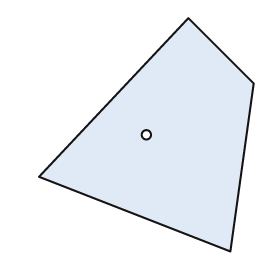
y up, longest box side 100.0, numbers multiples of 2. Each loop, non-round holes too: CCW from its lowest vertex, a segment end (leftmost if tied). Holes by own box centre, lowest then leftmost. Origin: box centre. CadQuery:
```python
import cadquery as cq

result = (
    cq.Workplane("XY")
    .moveTo(36.0, -50.0)
    .lineTo(46.0, 22.0)
    .lineTo(18.0, 50.0)
    .lineTo(-46.0, -18.0)
    .close()
    .moveTo(0.0, 0.0)
    .circle(2.0)
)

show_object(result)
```